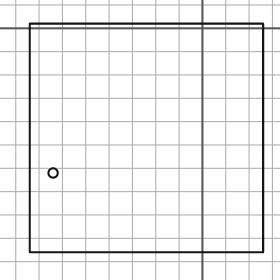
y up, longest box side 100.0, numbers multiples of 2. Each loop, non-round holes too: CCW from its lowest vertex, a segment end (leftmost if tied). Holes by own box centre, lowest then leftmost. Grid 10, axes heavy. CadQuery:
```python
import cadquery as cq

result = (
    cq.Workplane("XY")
    .moveTo(-74.0, -96.0)
    .lineTo(26.0, -96.0)
    .lineTo(26.0, 2.0)
    .lineTo(-74.0, 2.0)
    .close()
    .moveTo(-64.0, -62.0)
    .circle(2.0)
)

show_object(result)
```